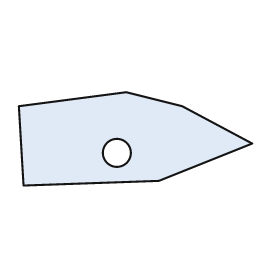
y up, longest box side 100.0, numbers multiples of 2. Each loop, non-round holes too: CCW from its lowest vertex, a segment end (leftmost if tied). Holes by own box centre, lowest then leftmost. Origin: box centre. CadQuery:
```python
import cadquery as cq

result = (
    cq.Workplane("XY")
    .moveTo(-48.0, -20.0)
    .lineTo(10.0, -18.0)
    .lineTo(50.0, -2.0)
    .lineTo(20.0, 14.0)
    .lineTo(-4.0, 20.0)
    .lineTo(-50.0, 14.0)
    .close()
    .moveTo(-8.0, -6.0)
    .circle(6.0)
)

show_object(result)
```